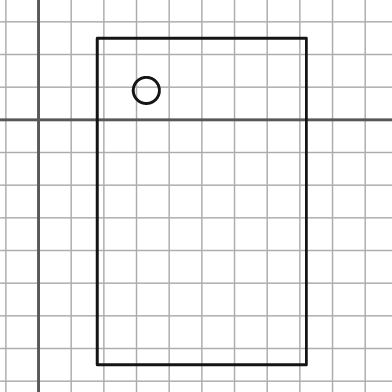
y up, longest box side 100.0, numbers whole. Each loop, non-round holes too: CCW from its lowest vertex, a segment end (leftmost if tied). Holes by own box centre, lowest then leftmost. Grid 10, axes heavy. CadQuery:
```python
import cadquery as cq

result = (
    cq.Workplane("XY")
    .moveTo(18.0, -75.0)
    .lineTo(82.0, -75.0)
    .lineTo(82.0, 25.0)
    .lineTo(18.0, 25.0)
    .close()
    .moveTo(33.0, 9.0)
    .circle(4.0)
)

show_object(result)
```